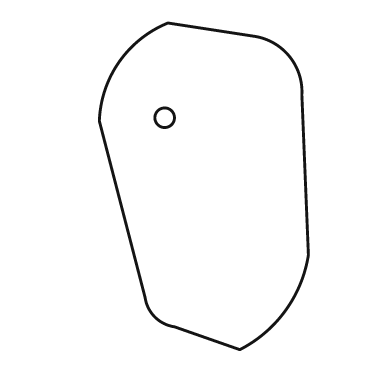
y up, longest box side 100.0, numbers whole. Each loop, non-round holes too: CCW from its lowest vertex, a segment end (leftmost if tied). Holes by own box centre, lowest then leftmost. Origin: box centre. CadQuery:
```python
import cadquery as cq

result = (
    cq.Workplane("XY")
    .moveTo(11.0, -50.0)
    .threePointArc((25.0, -38.0), (32.0, -21.0))
    .lineTo(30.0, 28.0)
    .threePointArc((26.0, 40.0), (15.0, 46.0))
    .lineTo(-11.0, 50.0)
    .threePointArc((-26.0, 38.0), (-32.0, 20.0))
    .lineTo(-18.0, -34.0)
    .threePointArc((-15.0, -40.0), (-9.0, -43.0))
    .close()
    .moveTo(-12.0, 21.0)
    .circle(3.0)
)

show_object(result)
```